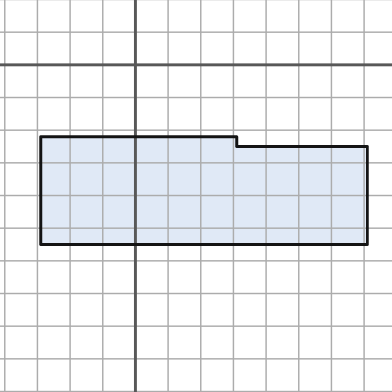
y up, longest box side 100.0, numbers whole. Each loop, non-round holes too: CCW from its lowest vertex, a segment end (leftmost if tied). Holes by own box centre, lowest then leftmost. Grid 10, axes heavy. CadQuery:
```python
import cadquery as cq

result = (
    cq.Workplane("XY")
    .moveTo(-29.0, -55.0)
    .lineTo(71.0, -55.0)
    .lineTo(71.0, -25.0)
    .lineTo(31.0, -25.0)
    .lineTo(31.0, -22.0)
    .lineTo(-29.0, -22.0)
    .close()
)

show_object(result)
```